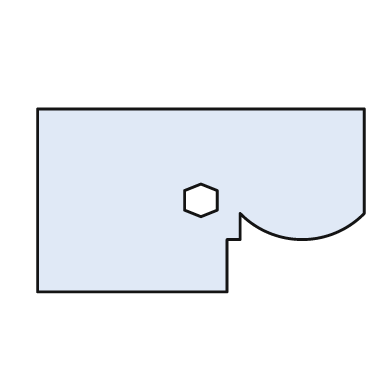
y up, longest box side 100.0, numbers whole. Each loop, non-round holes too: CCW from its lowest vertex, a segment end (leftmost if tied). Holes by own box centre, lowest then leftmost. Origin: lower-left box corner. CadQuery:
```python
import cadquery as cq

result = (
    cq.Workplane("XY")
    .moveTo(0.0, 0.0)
    .lineTo(58.0, 0.0)
    .lineTo(58.0, 16.0)
    .lineTo(62.0, 16.0)
    .lineTo(62.0, 24.0)
    .threePointArc((81.0, 16.0), (100.0, 24.0))
    .lineTo(100.0, 56.0)
    .lineTo(0.0, 56.0)
    .close()
    .moveTo(50.0, 23.0)
    .lineTo(55.0, 25.0)
    .lineTo(55.0, 31.0)
    .lineTo(50.0, 33.0)
    .lineTo(45.0, 31.0)
    .lineTo(45.0, 25.0)
    .close()
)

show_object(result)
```